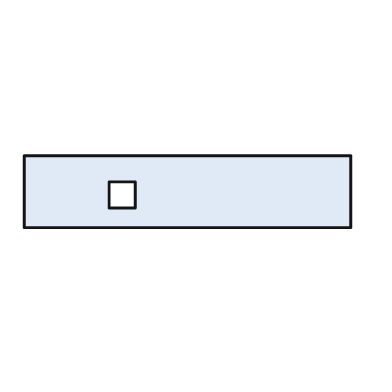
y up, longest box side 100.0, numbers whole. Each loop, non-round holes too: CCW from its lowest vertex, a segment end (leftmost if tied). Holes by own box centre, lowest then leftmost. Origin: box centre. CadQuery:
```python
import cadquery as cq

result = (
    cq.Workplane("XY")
    .moveTo(-50.0, -11.0)
    .lineTo(50.0, -11.0)
    .lineTo(50.0, 11.0)
    .lineTo(-50.0, 11.0)
    .close()
    .moveTo(-24.0, -5.0)
    .lineTo(-16.0, -5.0)
    .lineTo(-16.0, 3.0)
    .lineTo(-24.0, 3.0)
    .close()
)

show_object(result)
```